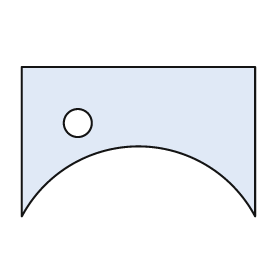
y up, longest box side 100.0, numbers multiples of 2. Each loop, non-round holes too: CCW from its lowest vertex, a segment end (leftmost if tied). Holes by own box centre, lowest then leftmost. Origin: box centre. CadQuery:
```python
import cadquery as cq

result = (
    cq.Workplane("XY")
    .moveTo(-50.0, -32.0)
    .threePointArc((0.0, -2.0), (50.0, -32.0))
    .lineTo(50.0, 32.0)
    .lineTo(-50.0, 32.0)
    .close()
    .moveTo(-26.0, 8.0)
    .circle(6.0)
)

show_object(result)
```